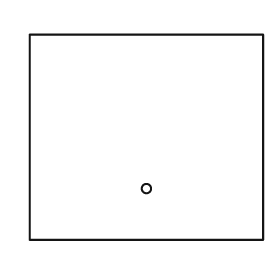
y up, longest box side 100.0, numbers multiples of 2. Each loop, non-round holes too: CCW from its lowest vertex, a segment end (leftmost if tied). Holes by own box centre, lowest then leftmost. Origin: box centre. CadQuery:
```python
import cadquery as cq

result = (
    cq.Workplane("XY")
    .moveTo(-50.0, -44.0)
    .lineTo(50.0, -44.0)
    .lineTo(50.0, 44.0)
    .lineTo(-50.0, 44.0)
    .close()
    .moveTo(0.0, -22.0)
    .circle(2.0)
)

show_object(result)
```